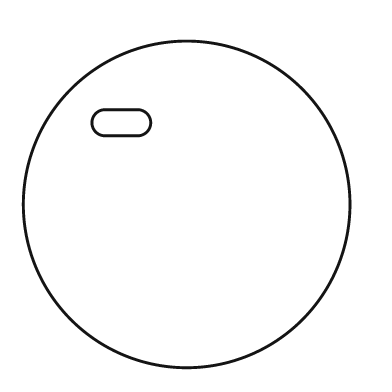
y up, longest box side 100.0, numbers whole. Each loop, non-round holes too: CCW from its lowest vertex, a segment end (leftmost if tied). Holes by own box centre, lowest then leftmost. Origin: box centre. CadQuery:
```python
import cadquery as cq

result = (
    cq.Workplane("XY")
    .moveTo(0.0, 0.0)
    .circle(50.0)
    .moveTo(-25.0, 21.0)
    .lineTo(-15.0, 21.0)
    .threePointArc((-11.0, 25.0), (-15.0, 29.0))
    .lineTo(-25.0, 29.0)
    .threePointArc((-29.0, 25.0), (-25.0, 21.0))
    .close()
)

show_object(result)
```